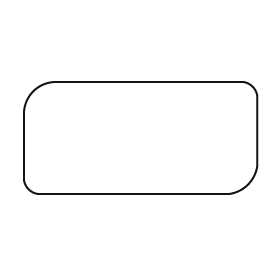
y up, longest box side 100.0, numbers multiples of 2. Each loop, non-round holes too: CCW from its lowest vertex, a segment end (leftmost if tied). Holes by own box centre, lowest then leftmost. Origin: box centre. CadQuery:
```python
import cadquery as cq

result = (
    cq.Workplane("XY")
    .moveTo(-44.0, -24.0)
    .lineTo(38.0, -24.0)
    .threePointArc((46.0, -20.0), (50.0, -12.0))
    .lineTo(50.0, 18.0)
    .threePointArc((48.0, 22.0), (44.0, 24.0))
    .lineTo(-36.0, 24.0)
    .threePointArc((-46.0, 20.0), (-50.0, 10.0))
    .lineTo(-50.0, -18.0)
    .threePointArc((-48.0, -22.0), (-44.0, -24.0))
    .close()
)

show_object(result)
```